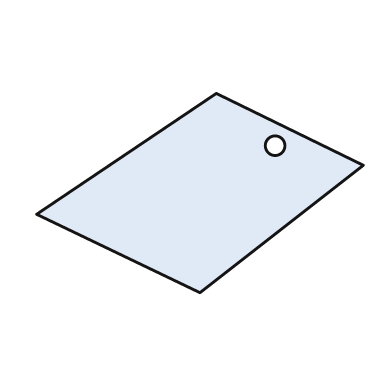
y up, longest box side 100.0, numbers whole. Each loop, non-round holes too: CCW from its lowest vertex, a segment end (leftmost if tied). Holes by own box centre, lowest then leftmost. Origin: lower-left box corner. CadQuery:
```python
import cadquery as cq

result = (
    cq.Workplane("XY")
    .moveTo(50.0, 0.0)
    .lineTo(100.0, 39.0)
    .lineTo(55.0, 61.0)
    .lineTo(0.0, 24.0)
    .close()
    .moveTo(73.0, 45.0)
    .circle(3.0)
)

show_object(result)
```